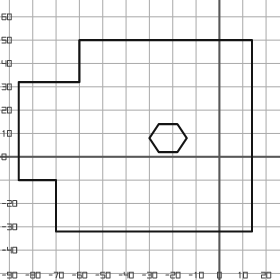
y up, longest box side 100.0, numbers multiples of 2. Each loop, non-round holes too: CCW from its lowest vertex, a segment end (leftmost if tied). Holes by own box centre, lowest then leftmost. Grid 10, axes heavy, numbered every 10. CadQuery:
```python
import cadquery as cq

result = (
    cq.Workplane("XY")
    .moveTo(-70.0, -32.0)
    .lineTo(14.0, -32.0)
    .lineTo(14.0, 50.0)
    .lineTo(-60.0, 50.0)
    .lineTo(-60.0, 32.0)
    .lineTo(-86.0, 32.0)
    .lineTo(-86.0, -10.0)
    .lineTo(-70.0, -10.0)
    .close()
    .moveTo(-26.0, 2.0)
    .lineTo(-18.0, 2.0)
    .lineTo(-14.0, 8.0)
    .lineTo(-18.0, 14.0)
    .lineTo(-26.0, 14.0)
    .lineTo(-30.0, 8.0)
    .close()
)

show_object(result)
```